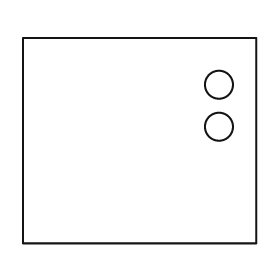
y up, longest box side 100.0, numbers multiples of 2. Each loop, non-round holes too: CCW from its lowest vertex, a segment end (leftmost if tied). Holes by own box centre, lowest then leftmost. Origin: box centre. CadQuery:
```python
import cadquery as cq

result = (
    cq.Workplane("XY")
    .moveTo(-50.0, -44.0)
    .lineTo(50.0, -44.0)
    .lineTo(50.0, 44.0)
    .lineTo(-50.0, 44.0)
    .close()
    .moveTo(34.0, 6.0)
    .circle(6.0)
    .moveTo(34.0, 24.0)
    .circle(6.0)
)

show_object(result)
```